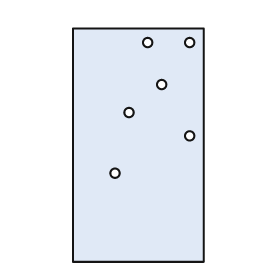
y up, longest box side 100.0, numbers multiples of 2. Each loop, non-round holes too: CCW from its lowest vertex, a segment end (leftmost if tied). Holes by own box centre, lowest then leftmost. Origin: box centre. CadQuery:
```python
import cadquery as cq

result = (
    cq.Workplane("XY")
    .moveTo(-28.0, -50.0)
    .lineTo(28.0, -50.0)
    .lineTo(28.0, 50.0)
    .lineTo(-28.0, 50.0)
    .close()
    .moveTo(-10.0, -12.0)
    .circle(2.0)
    .moveTo(22.0, 4.0)
    .circle(2.0)
    .moveTo(-4.0, 14.0)
    .circle(2.0)
    .moveTo(10.0, 26.0)
    .circle(2.0)
    .moveTo(4.0, 44.0)
    .circle(2.0)
    .moveTo(22.0, 44.0)
    .circle(2.0)
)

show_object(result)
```